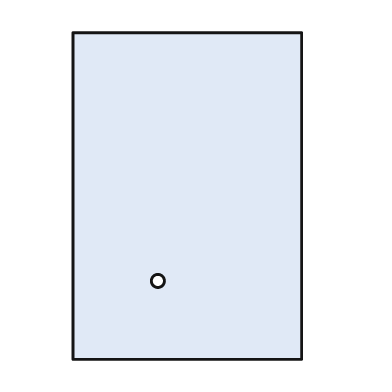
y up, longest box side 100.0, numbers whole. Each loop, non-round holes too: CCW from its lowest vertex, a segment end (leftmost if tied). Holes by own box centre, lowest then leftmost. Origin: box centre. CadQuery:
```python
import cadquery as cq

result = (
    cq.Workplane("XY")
    .moveTo(-35.0, -50.0)
    .lineTo(35.0, -50.0)
    .lineTo(35.0, 50.0)
    .lineTo(-35.0, 50.0)
    .close()
    .moveTo(-9.0, -26.0)
    .circle(2.0)
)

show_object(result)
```